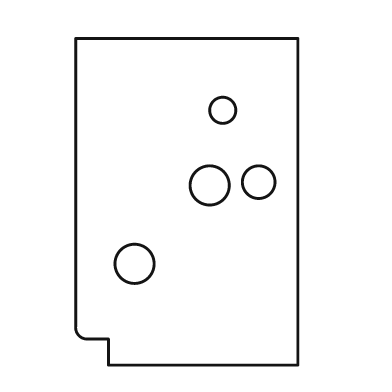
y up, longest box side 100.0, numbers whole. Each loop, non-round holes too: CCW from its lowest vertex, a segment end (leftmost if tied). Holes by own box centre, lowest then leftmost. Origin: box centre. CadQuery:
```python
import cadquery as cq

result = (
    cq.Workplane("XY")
    .moveTo(-24.0, -50.0)
    .lineTo(34.0, -50.0)
    .lineTo(34.0, 50.0)
    .lineTo(-34.0, 50.0)
    .lineTo(-34.0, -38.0)
    .threePointArc((-33.0, -41.0), (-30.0, -42.0))
    .lineTo(-24.0, -42.0)
    .close()
    .moveTo(-16.0, -19.0)
    .circle(6.0)
    .moveTo(7.0, 5.0)
    .circle(6.0)
    .moveTo(22.0, 6.0)
    .circle(5.0)
    .moveTo(11.0, 28.0)
    .circle(4.0)
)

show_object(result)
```